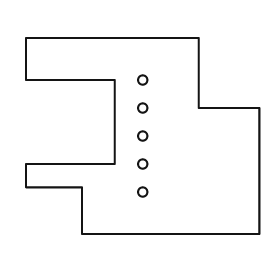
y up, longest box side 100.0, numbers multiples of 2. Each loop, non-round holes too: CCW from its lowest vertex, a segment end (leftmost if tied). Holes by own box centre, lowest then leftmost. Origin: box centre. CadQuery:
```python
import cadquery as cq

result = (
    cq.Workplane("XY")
    .moveTo(-26.0, -42.0)
    .lineTo(50.0, -42.0)
    .lineTo(50.0, 12.0)
    .lineTo(24.0, 12.0)
    .lineTo(24.0, 42.0)
    .lineTo(-50.0, 42.0)
    .lineTo(-50.0, 24.0)
    .lineTo(-12.0, 24.0)
    .lineTo(-12.0, -12.0)
    .lineTo(-50.0, -12.0)
    .lineTo(-50.0, -22.0)
    .lineTo(-26.0, -22.0)
    .close()
    .moveTo(0.0, -24.0)
    .circle(2.0)
    .moveTo(0.0, -12.0)
    .circle(2.0)
    .moveTo(0.0, 0.0)
    .circle(2.0)
    .moveTo(0.0, 12.0)
    .circle(2.0)
    .moveTo(0.0, 24.0)
    .circle(2.0)
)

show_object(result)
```